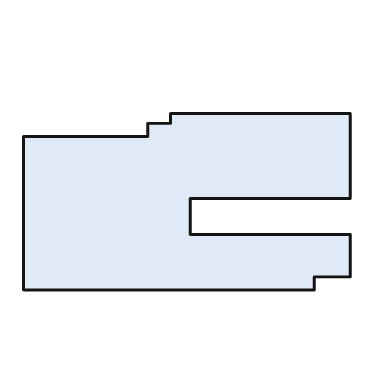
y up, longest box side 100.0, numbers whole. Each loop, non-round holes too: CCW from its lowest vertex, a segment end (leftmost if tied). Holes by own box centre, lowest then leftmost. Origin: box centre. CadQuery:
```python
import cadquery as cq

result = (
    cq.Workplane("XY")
    .moveTo(-50.0, -27.0)
    .lineTo(39.0, -27.0)
    .lineTo(39.0, -23.0)
    .lineTo(50.0, -23.0)
    .lineTo(50.0, -10.0)
    .lineTo(1.0, -10.0)
    .lineTo(1.0, 1.0)
    .lineTo(50.0, 1.0)
    .lineTo(50.0, 27.0)
    .lineTo(-5.0, 27.0)
    .lineTo(-5.0, 24.0)
    .lineTo(-12.0, 24.0)
    .lineTo(-12.0, 20.0)
    .lineTo(-50.0, 20.0)
    .close()
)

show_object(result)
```